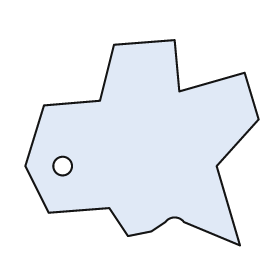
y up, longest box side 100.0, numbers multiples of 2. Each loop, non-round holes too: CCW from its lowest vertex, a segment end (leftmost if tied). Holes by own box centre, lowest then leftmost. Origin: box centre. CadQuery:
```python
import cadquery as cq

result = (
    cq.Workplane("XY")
    .moveTo(42.0, -44.0)
    .lineTo(32.0, -10.0)
    .lineTo(50.0, 10.0)
    .lineTo(44.0, 30.0)
    .lineTo(16.0, 22.0)
    .lineTo(14.0, 44.0)
    .lineTo(-12.0, 42.0)
    .lineTo(-18.0, 18.0)
    .lineTo(-42.0, 16.0)
    .lineTo(-50.0, -10.0)
    .lineTo(-40.0, -30.0)
    .lineTo(-14.0, -28.0)
    .lineTo(-6.0, -40.0)
    .lineTo(4.0, -38.0)
    .lineTo(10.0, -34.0)
    .threePointArc((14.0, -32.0), (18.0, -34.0))
    .close()
    .moveTo(-34.0, -10.0)
    .circle(4.0)
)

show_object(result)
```